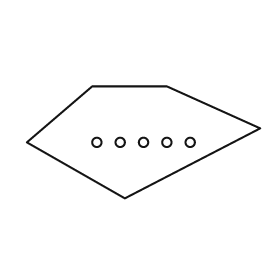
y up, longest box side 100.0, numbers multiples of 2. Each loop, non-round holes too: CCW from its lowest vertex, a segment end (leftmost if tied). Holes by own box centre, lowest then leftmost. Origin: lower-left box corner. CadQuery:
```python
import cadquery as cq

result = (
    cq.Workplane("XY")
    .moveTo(42.0, 0.0)
    .lineTo(100.0, 30.0)
    .lineTo(60.0, 48.0)
    .lineTo(28.0, 48.0)
    .lineTo(0.0, 24.0)
    .close()
    .moveTo(30.0, 24.0)
    .circle(2.0)
    .moveTo(40.0, 24.0)
    .circle(2.0)
    .moveTo(50.0, 24.0)
    .circle(2.0)
    .moveTo(60.0, 24.0)
    .circle(2.0)
    .moveTo(70.0, 24.0)
    .circle(2.0)
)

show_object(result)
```